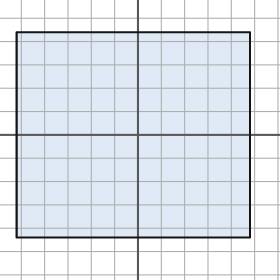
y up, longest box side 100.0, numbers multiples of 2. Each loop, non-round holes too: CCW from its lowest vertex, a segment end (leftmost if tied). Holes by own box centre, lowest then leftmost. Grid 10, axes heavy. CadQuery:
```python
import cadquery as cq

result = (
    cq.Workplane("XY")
    .moveTo(-52.0, -44.0)
    .lineTo(48.0, -44.0)
    .lineTo(48.0, 44.0)
    .lineTo(-52.0, 44.0)
    .close()
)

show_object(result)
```